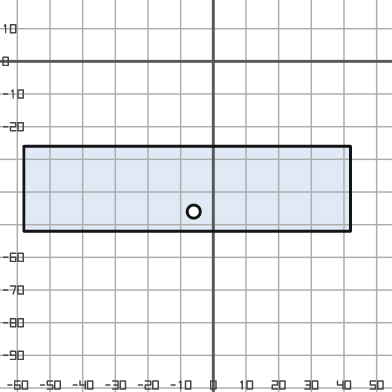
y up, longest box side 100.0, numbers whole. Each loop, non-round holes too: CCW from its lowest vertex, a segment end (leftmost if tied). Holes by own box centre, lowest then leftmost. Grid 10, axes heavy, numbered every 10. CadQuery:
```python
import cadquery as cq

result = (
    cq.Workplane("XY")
    .moveTo(-58.0, -52.0)
    .lineTo(42.0, -52.0)
    .lineTo(42.0, -26.0)
    .lineTo(-58.0, -26.0)
    .close()
    .moveTo(-6.0, -46.0)
    .circle(2.0)
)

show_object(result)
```